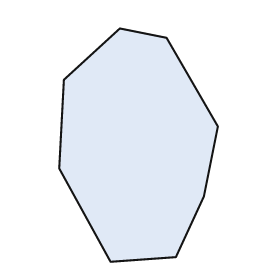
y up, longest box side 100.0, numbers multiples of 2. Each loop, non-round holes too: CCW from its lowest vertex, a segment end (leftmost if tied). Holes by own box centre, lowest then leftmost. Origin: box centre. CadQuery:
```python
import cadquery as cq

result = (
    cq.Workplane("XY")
    .moveTo(-12.0, -50.0)
    .lineTo(16.0, -48.0)
    .lineTo(28.0, -22.0)
    .lineTo(34.0, 8.0)
    .lineTo(12.0, 46.0)
    .lineTo(-8.0, 50.0)
    .lineTo(-32.0, 28.0)
    .lineTo(-34.0, -10.0)
    .close()
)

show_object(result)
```